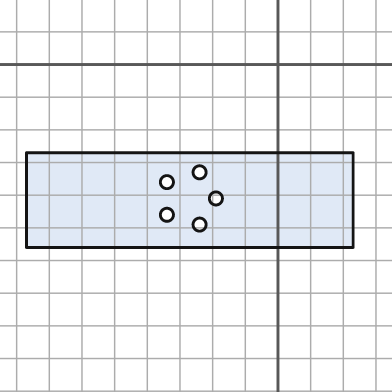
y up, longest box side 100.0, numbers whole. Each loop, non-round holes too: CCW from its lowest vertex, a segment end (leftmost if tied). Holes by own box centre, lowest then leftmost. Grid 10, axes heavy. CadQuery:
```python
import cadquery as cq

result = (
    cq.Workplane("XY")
    .moveTo(-77.0, -56.0)
    .lineTo(23.0, -56.0)
    .lineTo(23.0, -27.0)
    .lineTo(-77.0, -27.0)
    .close()
    .moveTo(-24.0, -49.0)
    .circle(2.0)
    .moveTo(-34.0, -46.0)
    .circle(2.0)
    .moveTo(-19.0, -41.0)
    .circle(2.0)
    .moveTo(-34.0, -36.0)
    .circle(2.0)
    .moveTo(-24.0, -33.0)
    .circle(2.0)
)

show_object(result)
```